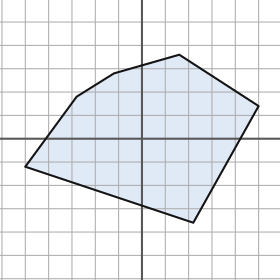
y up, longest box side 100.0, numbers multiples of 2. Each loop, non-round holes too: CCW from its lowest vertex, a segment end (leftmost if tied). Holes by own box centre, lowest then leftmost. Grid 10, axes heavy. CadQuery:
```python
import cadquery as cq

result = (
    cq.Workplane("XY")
    .moveTo(22.0, -36.0)
    .lineTo(50.0, 14.0)
    .lineTo(16.0, 36.0)
    .lineTo(-12.0, 28.0)
    .lineTo(-28.0, 18.0)
    .lineTo(-50.0, -12.0)
    .close()
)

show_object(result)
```